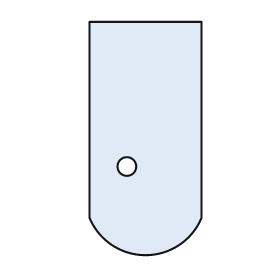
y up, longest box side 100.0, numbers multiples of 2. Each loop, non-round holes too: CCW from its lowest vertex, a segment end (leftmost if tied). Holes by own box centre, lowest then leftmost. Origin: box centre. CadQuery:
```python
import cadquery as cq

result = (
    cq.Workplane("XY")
    .moveTo(-24.0, -34.0)
    .threePointArc((0.0, -50.0), (24.0, -34.0))
    .lineTo(24.0, 50.0)
    .lineTo(-24.0, 50.0)
    .close()
    .moveTo(-8.0, -12.0)
    .circle(4.0)
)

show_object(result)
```